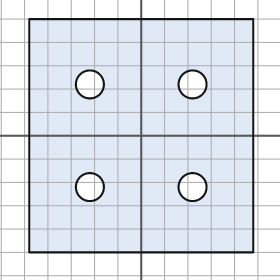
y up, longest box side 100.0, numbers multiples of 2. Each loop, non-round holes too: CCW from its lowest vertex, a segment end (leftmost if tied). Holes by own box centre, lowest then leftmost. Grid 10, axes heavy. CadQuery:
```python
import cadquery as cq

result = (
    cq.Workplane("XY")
    .moveTo(-48.0, -50.0)
    .lineTo(48.0, -50.0)
    .lineTo(48.0, 50.0)
    .lineTo(-48.0, 50.0)
    .close()
    .moveTo(-22.0, -22.0)
    .circle(6.0)
    .moveTo(22.0, -22.0)
    .circle(6.0)
    .moveTo(-22.0, 22.0)
    .circle(6.0)
    .moveTo(22.0, 22.0)
    .circle(6.0)
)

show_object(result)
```